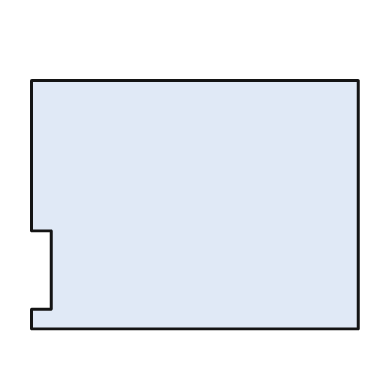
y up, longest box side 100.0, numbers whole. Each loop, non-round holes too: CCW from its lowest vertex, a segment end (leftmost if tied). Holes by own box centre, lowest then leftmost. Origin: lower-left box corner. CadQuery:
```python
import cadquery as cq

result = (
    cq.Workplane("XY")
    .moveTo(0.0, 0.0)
    .lineTo(100.0, 0.0)
    .lineTo(100.0, 76.0)
    .lineTo(0.0, 76.0)
    .lineTo(0.0, 30.0)
    .lineTo(6.0, 30.0)
    .lineTo(6.0, 6.0)
    .lineTo(0.0, 6.0)
    .close()
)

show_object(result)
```